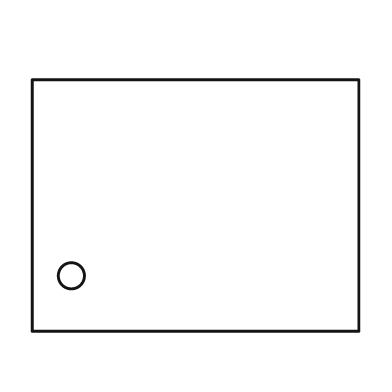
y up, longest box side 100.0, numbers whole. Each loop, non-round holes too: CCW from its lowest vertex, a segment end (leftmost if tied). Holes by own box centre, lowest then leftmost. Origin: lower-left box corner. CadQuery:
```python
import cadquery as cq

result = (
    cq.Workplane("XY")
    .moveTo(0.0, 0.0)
    .lineTo(100.0, 0.0)
    .lineTo(100.0, 77.0)
    .lineTo(0.0, 77.0)
    .close()
    .moveTo(12.0, 17.0)
    .circle(4.0)
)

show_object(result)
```